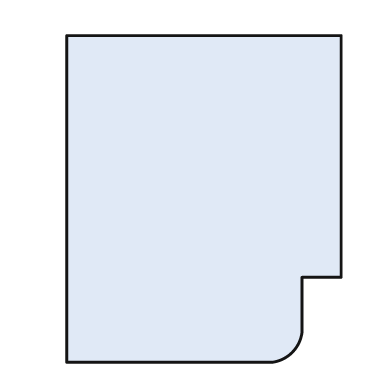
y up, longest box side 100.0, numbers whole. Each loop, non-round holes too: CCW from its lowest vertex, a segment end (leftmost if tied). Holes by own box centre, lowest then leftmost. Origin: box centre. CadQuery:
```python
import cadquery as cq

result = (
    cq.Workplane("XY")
    .moveTo(-42.0, -50.0)
    .lineTo(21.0, -50.0)
    .threePointArc((27.0, -47.0), (30.0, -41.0))
    .lineTo(30.0, -24.0)
    .lineTo(42.0, -24.0)
    .lineTo(42.0, 50.0)
    .lineTo(-42.0, 50.0)
    .close()
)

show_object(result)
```